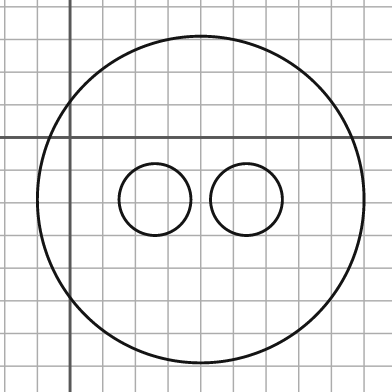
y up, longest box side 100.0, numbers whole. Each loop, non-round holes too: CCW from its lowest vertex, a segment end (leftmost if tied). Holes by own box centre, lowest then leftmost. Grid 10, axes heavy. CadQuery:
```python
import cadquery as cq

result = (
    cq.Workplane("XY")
    .moveTo(40.0, -19.0)
    .circle(50.0)
    .moveTo(26.0, -19.0)
    .circle(11.0)
    .moveTo(54.0, -19.0)
    .circle(11.0)
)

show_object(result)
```